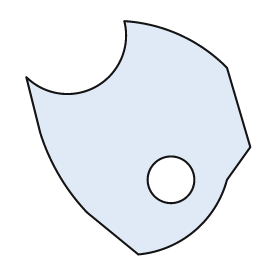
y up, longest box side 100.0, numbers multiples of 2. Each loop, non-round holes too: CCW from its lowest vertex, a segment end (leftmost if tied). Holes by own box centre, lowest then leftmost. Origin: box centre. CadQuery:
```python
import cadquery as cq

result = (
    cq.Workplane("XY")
    .moveTo(0.0, -50.0)
    .threePointArc((24.0, -40.0), (38.0, -18.0))
    .lineTo(48.0, -4.0)
    .lineTo(38.0, 30.0)
    .threePointArc((18.0, 44.0), (-6.0, 50.0))
    .threePointArc((-18.0, 22.0), (-48.0, 26.0))
    .lineTo(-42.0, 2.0)
    .threePointArc((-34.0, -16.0), (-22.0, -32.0))
    .close()
    .moveTo(14.0, -18.0)
    .circle(10.0)
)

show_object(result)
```